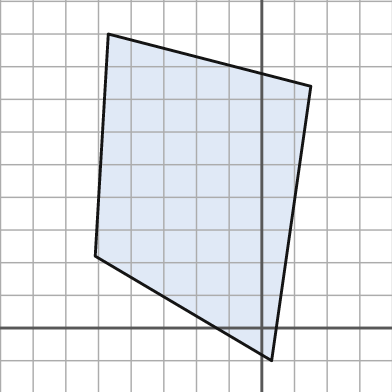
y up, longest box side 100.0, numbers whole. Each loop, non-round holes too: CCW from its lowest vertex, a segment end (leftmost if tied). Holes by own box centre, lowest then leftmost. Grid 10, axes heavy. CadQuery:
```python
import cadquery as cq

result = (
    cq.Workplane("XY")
    .moveTo(3.0, -10.0)
    .lineTo(15.0, 74.0)
    .lineTo(-47.0, 90.0)
    .lineTo(-51.0, 22.0)
    .close()
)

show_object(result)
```